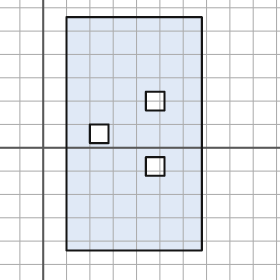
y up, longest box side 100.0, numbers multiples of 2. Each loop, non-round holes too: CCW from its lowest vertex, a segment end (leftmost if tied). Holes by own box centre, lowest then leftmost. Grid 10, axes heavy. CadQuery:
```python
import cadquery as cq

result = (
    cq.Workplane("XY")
    .moveTo(10.0, -44.0)
    .lineTo(68.0, -44.0)
    .lineTo(68.0, 56.0)
    .lineTo(10.0, 56.0)
    .close()
    .moveTo(44.0, -12.0)
    .lineTo(52.0, -12.0)
    .lineTo(52.0, -4.0)
    .lineTo(44.0, -4.0)
    .close()
    .moveTo(20.0, 2.0)
    .lineTo(28.0, 2.0)
    .lineTo(28.0, 10.0)
    .lineTo(20.0, 10.0)
    .close()
    .moveTo(44.0, 16.0)
    .lineTo(52.0, 16.0)
    .lineTo(52.0, 24.0)
    .lineTo(44.0, 24.0)
    .close()
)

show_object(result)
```